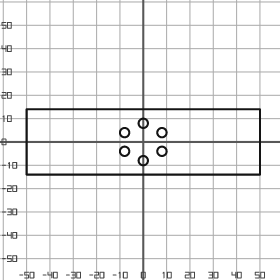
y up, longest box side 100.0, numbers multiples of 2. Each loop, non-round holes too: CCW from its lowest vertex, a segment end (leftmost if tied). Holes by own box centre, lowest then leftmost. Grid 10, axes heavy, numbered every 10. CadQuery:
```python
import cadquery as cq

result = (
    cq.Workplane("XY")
    .moveTo(-50.0, -14.0)
    .lineTo(50.0, -14.0)
    .lineTo(50.0, 14.0)
    .lineTo(-50.0, 14.0)
    .close()
    .moveTo(0.0, -8.0)
    .circle(2.0)
    .moveTo(-8.0, -4.0)
    .circle(2.0)
    .moveTo(8.0, -4.0)
    .circle(2.0)
    .moveTo(-8.0, 4.0)
    .circle(2.0)
    .moveTo(8.0, 4.0)
    .circle(2.0)
    .moveTo(0.0, 8.0)
    .circle(2.0)
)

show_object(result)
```